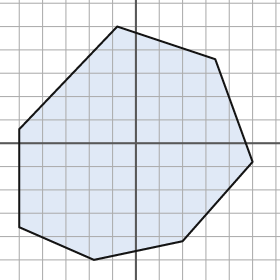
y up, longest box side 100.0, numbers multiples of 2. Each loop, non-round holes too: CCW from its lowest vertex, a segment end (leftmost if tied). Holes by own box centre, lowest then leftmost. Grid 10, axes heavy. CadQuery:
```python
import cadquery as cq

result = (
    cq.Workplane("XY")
    .moveTo(-18.0, -50.0)
    .lineTo(20.0, -42.0)
    .lineTo(50.0, -8.0)
    .lineTo(34.0, 36.0)
    .lineTo(-8.0, 50.0)
    .lineTo(-50.0, 6.0)
    .lineTo(-50.0, -36.0)
    .close()
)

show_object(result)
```